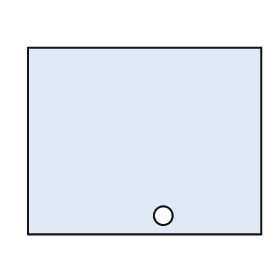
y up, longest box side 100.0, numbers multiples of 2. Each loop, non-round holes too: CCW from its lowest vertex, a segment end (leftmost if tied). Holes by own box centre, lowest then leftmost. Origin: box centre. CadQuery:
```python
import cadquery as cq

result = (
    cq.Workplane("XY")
    .moveTo(-50.0, -40.0)
    .lineTo(50.0, -40.0)
    .lineTo(50.0, 40.0)
    .lineTo(-50.0, 40.0)
    .close()
    .moveTo(8.0, -32.0)
    .circle(4.0)
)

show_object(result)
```